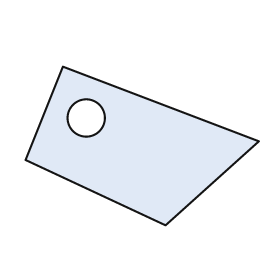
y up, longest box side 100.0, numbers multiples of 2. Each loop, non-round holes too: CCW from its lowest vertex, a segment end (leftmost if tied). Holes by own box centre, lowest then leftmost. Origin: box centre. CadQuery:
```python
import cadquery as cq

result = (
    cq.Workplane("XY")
    .moveTo(10.0, -34.0)
    .lineTo(50.0, 2.0)
    .lineTo(-34.0, 34.0)
    .lineTo(-50.0, -6.0)
    .close()
    .moveTo(-24.0, 12.0)
    .circle(8.0)
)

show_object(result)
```